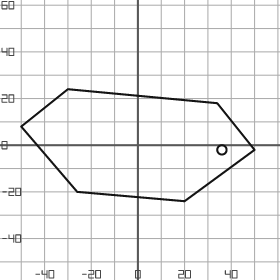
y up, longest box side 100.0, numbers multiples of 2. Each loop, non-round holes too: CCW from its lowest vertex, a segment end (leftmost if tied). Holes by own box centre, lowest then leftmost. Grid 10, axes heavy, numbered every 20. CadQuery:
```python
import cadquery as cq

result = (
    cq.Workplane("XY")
    .moveTo(20.0, -24.0)
    .lineTo(50.0, -2.0)
    .lineTo(34.0, 18.0)
    .lineTo(-30.0, 24.0)
    .lineTo(-50.0, 8.0)
    .lineTo(-26.0, -20.0)
    .close()
    .moveTo(36.0, -2.0)
    .circle(2.0)
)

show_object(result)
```